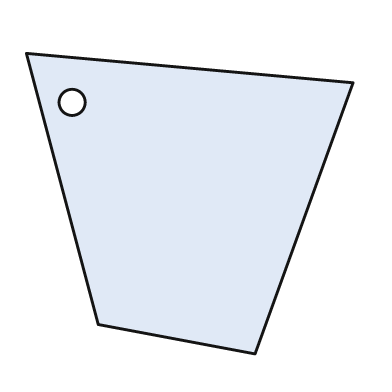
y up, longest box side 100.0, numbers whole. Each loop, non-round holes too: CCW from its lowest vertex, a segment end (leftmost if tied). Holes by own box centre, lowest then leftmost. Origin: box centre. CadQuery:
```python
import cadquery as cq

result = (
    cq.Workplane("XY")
    .moveTo(20.0, -46.0)
    .lineTo(50.0, 37.0)
    .lineTo(-50.0, 46.0)
    .lineTo(-28.0, -37.0)
    .close()
    .moveTo(-36.0, 31.0)
    .circle(4.0)
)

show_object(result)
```